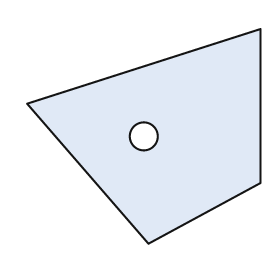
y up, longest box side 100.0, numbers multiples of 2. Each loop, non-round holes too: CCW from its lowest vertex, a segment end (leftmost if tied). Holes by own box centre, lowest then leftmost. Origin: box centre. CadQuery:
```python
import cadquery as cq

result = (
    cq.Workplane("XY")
    .moveTo(2.0, -46.0)
    .lineTo(50.0, -20.0)
    .lineTo(50.0, 46.0)
    .lineTo(-50.0, 14.0)
    .close()
    .moveTo(0.0, 0.0)
    .circle(6.0)
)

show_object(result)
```